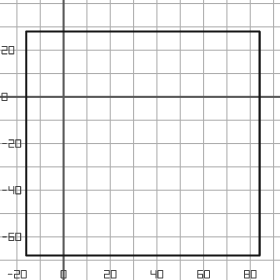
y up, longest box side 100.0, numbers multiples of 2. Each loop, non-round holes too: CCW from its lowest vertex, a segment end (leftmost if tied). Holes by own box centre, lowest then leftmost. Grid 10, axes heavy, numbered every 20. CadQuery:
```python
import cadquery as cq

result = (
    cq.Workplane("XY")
    .moveTo(-16.0, -68.0)
    .lineTo(84.0, -68.0)
    .lineTo(84.0, 28.0)
    .lineTo(-16.0, 28.0)
    .close()
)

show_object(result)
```